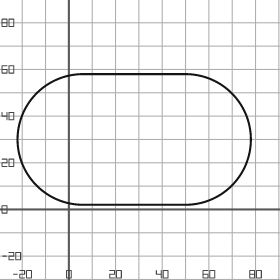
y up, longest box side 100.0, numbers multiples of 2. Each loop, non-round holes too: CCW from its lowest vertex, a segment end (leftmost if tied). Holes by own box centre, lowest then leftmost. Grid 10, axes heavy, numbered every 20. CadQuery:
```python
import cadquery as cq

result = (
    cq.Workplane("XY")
    .moveTo(6.0, 2.0)
    .lineTo(50.0, 2.0)
    .threePointArc((78.0, 30.0), (50.0, 58.0))
    .lineTo(6.0, 58.0)
    .threePointArc((-22.0, 30.0), (6.0, 2.0))
    .close()
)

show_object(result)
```